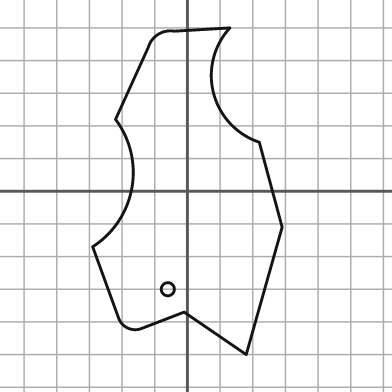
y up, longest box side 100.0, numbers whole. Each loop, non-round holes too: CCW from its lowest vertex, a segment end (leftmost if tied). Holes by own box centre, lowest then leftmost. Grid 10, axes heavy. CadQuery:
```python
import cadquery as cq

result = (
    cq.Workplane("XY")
    .moveTo(18.0, -50.0)
    .lineTo(29.0, -11.0)
    .lineTo(22.0, 15.0)
    .threePointArc((8.0, 30.0), (13.0, 50.0))
    .lineTo(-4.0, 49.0)
    .threePointArc((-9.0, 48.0), (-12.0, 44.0))
    .lineTo(-22.0, 22.0)
    .threePointArc((-17.0, 1.0), (-29.0, -17.0))
    .lineTo(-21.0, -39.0)
    .threePointArc((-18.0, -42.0), (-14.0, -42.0))
    .lineTo(-1.0, -37.0)
    .close()
    .moveTo(-6.0, -30.0)
    .circle(2.0)
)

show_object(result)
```